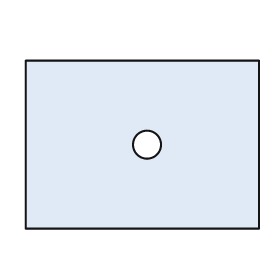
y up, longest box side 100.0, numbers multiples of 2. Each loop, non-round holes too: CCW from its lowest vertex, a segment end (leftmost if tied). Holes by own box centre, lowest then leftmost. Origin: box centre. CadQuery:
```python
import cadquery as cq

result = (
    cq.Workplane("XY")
    .moveTo(-50.0, -36.0)
    .lineTo(50.0, -36.0)
    .lineTo(50.0, 36.0)
    .lineTo(-50.0, 36.0)
    .close()
    .moveTo(2.0, 0.0)
    .circle(6.0)
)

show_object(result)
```